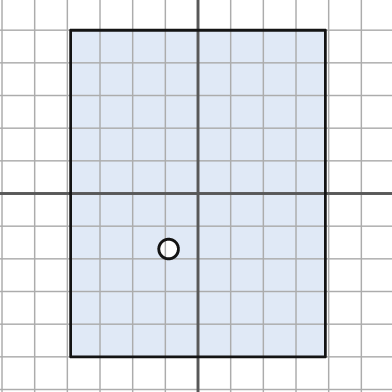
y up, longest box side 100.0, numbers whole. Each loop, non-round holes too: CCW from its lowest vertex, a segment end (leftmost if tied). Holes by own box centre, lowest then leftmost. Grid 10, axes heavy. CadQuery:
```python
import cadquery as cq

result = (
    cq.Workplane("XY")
    .moveTo(-39.0, -50.0)
    .lineTo(39.0, -50.0)
    .lineTo(39.0, 50.0)
    .lineTo(-39.0, 50.0)
    .close()
    .moveTo(-9.0, -17.0)
    .circle(3.0)
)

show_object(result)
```